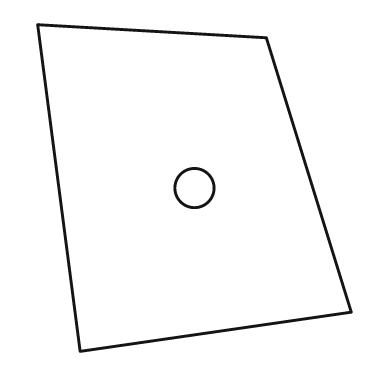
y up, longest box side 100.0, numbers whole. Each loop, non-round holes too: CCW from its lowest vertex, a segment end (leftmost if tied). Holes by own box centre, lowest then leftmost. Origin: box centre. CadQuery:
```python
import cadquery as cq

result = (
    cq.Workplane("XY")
    .moveTo(-35.0, -50.0)
    .lineTo(48.0, -38.0)
    .lineTo(22.0, 46.0)
    .lineTo(-48.0, 50.0)
    .close()
    .moveTo(0.0, 0.0)
    .circle(6.0)
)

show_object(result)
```